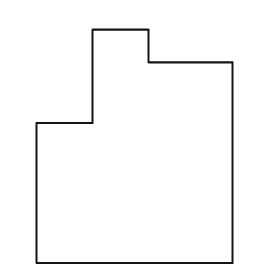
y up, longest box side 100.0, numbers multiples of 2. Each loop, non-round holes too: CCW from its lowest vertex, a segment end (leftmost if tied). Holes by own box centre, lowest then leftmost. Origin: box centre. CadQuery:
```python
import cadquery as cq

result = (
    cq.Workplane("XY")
    .moveTo(-42.0, -50.0)
    .lineTo(42.0, -50.0)
    .lineTo(42.0, 36.0)
    .lineTo(6.0, 36.0)
    .lineTo(6.0, 50.0)
    .lineTo(-18.0, 50.0)
    .lineTo(-18.0, 10.0)
    .lineTo(-42.0, 10.0)
    .close()
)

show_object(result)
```